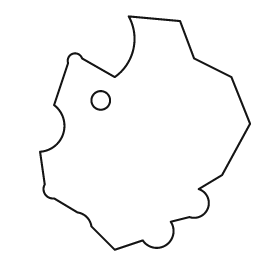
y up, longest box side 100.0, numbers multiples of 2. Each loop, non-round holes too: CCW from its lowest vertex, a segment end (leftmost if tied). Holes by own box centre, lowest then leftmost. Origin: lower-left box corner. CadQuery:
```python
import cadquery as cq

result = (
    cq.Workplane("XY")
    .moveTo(32.0, 0.0)
    .lineTo(44.0, 4.0)
    .threePointArc((54.0, 2.0), (56.0, 12.0))
    .lineTo(64.0, 14.0)
    .threePointArc((72.0, 18.0), (68.0, 26.0))
    .lineTo(78.0, 32.0)
    .lineTo(90.0, 54.0)
    .lineTo(82.0, 74.0)
    .lineTo(66.0, 82.0)
    .lineTo(60.0, 98.0)
    .lineTo(38.0, 100.0)
    .threePointArc((40.0, 86.0), (32.0, 74.0))
    .lineTo(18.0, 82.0)
    .threePointArc((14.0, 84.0), (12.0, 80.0))
    .lineTo(6.0, 62.0)
    .threePointArc((10.0, 50.0), (0.0, 42.0))
    .lineTo(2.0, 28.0)
    .threePointArc((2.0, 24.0), (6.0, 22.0))
    .lineTo(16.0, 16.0)
    .threePointArc((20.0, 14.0), (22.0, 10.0))
    .close()
    .moveTo(26.0, 64.0)
    .circle(4.0)
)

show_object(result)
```